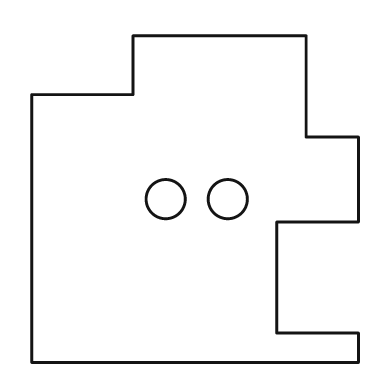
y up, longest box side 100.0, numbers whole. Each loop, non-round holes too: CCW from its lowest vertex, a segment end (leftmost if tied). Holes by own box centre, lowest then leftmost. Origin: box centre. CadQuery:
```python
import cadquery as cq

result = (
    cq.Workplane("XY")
    .moveTo(-50.0, -50.0)
    .lineTo(50.0, -50.0)
    .lineTo(50.0, -41.0)
    .lineTo(25.0, -41.0)
    .lineTo(25.0, -7.0)
    .lineTo(50.0, -7.0)
    .lineTo(50.0, 19.0)
    .lineTo(34.0, 19.0)
    .lineTo(34.0, 50.0)
    .lineTo(-19.0, 50.0)
    .lineTo(-19.0, 32.0)
    .lineTo(-50.0, 32.0)
    .close()
    .moveTo(-9.0, 0.0)
    .circle(6.0)
    .moveTo(10.0, 0.0)
    .circle(6.0)
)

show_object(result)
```